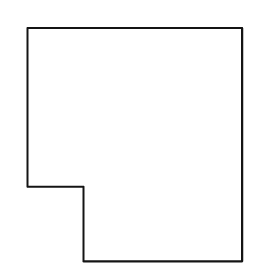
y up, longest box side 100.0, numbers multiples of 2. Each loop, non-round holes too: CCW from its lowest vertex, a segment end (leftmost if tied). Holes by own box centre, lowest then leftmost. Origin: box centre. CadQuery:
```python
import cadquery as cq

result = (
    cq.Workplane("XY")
    .moveTo(-22.0, -50.0)
    .lineTo(46.0, -50.0)
    .lineTo(46.0, 50.0)
    .lineTo(-46.0, 50.0)
    .lineTo(-46.0, -18.0)
    .lineTo(-22.0, -18.0)
    .close()
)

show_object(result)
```